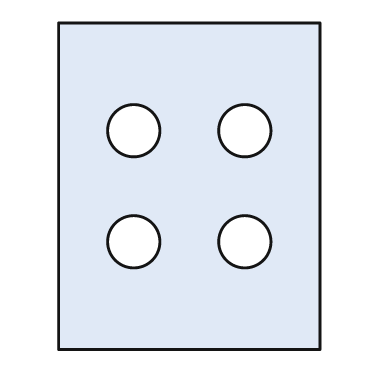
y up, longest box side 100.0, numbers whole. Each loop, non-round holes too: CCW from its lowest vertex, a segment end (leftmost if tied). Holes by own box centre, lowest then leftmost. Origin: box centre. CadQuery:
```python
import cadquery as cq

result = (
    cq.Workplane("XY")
    .moveTo(-40.0, -50.0)
    .lineTo(40.0, -50.0)
    .lineTo(40.0, 50.0)
    .lineTo(-40.0, 50.0)
    .close()
    .moveTo(-17.0, -17.0)
    .circle(8.0)
    .moveTo(17.0, -17.0)
    .circle(8.0)
    .moveTo(-17.0, 17.0)
    .circle(8.0)
    .moveTo(17.0, 17.0)
    .circle(8.0)
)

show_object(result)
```